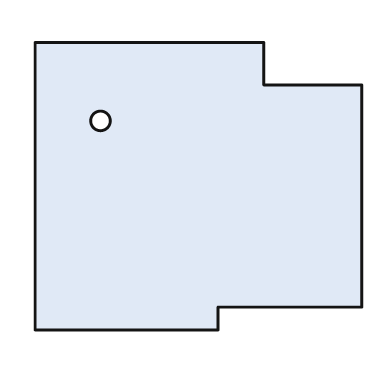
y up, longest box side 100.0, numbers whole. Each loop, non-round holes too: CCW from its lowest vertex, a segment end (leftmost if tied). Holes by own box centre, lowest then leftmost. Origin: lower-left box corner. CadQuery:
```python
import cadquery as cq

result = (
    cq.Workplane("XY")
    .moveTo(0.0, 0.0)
    .lineTo(56.0, 0.0)
    .lineTo(56.0, 7.0)
    .lineTo(100.0, 7.0)
    .lineTo(100.0, 75.0)
    .lineTo(70.0, 75.0)
    .lineTo(70.0, 88.0)
    .lineTo(0.0, 88.0)
    .close()
    .moveTo(20.0, 64.0)
    .circle(3.0)
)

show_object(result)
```